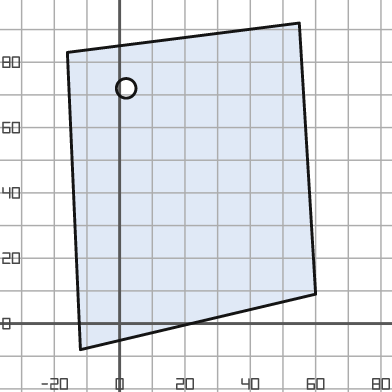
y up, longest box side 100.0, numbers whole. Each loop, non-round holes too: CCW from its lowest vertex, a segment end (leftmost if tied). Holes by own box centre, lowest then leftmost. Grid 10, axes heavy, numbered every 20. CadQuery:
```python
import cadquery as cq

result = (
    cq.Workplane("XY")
    .moveTo(-12.0, -8.0)
    .lineTo(60.0, 9.0)
    .lineTo(55.0, 92.0)
    .lineTo(-16.0, 83.0)
    .close()
    .moveTo(2.0, 72.0)
    .circle(3.0)
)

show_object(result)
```